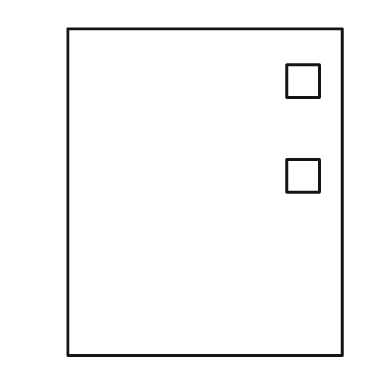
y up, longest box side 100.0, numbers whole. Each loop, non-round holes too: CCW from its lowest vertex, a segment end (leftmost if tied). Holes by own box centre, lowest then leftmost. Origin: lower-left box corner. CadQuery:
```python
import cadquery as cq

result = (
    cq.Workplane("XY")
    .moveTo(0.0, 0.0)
    .lineTo(84.0, 0.0)
    .lineTo(84.0, 100.0)
    .lineTo(0.0, 100.0)
    .close()
    .moveTo(67.0, 50.0)
    .lineTo(77.0, 50.0)
    .lineTo(77.0, 60.0)
    .lineTo(67.0, 60.0)
    .close()
    .moveTo(67.0, 79.0)
    .lineTo(77.0, 79.0)
    .lineTo(77.0, 89.0)
    .lineTo(67.0, 89.0)
    .close()
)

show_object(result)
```